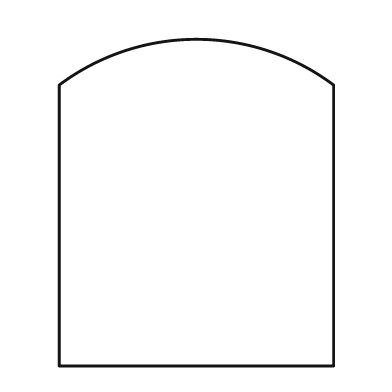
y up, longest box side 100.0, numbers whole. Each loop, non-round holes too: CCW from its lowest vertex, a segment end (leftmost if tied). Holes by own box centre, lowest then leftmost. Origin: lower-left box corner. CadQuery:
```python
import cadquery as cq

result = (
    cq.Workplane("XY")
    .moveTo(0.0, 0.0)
    .lineTo(84.0, 0.0)
    .lineTo(84.0, 86.0)
    .threePointArc((42.0, 100.0), (0.0, 86.0))
    .close()
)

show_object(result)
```